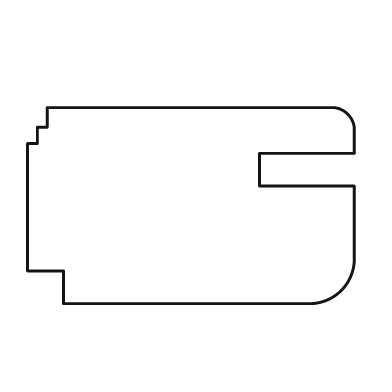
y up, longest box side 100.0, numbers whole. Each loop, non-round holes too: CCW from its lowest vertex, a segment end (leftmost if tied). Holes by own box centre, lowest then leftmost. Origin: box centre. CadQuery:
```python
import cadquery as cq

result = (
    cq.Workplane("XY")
    .moveTo(-39.0, -30.0)
    .lineTo(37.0, -30.0)
    .threePointArc((46.0, -26.0), (50.0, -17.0))
    .lineTo(50.0, 6.0)
    .lineTo(21.0, 6.0)
    .lineTo(21.0, 16.0)
    .lineTo(50.0, 16.0)
    .lineTo(50.0, 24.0)
    .threePointArc((48.0, 28.0), (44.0, 30.0))
    .lineTo(-44.0, 30.0)
    .lineTo(-44.0, 24.0)
    .lineTo(-47.0, 24.0)
    .lineTo(-47.0, 19.0)
    .lineTo(-50.0, 19.0)
    .lineTo(-50.0, -20.0)
    .lineTo(-39.0, -20.0)
    .close()
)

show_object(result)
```